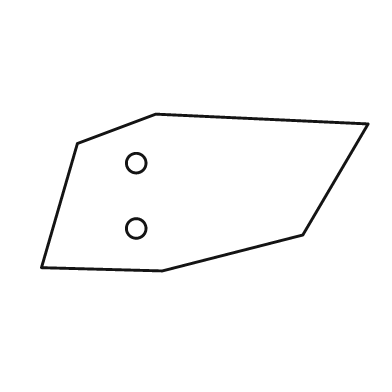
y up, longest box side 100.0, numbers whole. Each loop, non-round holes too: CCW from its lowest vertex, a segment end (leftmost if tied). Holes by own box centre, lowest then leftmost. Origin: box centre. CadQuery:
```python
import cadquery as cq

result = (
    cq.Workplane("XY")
    .moveTo(-13.0, -24.0)
    .lineTo(30.0, -13.0)
    .lineTo(50.0, 21.0)
    .lineTo(-15.0, 24.0)
    .lineTo(-39.0, 15.0)
    .lineTo(-50.0, -23.0)
    .close()
    .moveTo(-21.0, -11.0)
    .circle(3.0)
    .moveTo(-21.0, 9.0)
    .circle(3.0)
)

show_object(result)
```